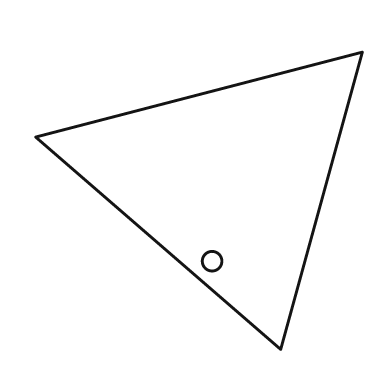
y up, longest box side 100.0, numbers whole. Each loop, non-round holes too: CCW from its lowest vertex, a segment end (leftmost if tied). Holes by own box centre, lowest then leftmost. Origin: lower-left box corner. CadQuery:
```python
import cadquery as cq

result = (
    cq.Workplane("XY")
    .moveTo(75.0, 0.0)
    .lineTo(100.0, 91.0)
    .lineTo(0.0, 65.0)
    .close()
    .moveTo(54.0, 27.0)
    .circle(3.0)
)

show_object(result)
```